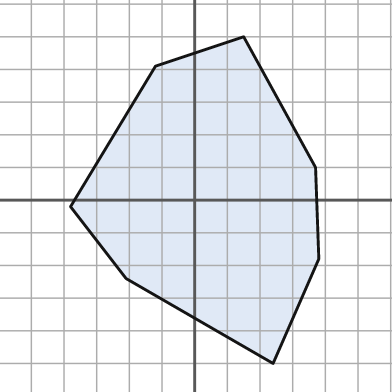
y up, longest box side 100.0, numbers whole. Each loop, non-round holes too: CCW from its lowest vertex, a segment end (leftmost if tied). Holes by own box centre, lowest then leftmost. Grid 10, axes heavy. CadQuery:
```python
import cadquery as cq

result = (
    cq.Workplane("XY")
    .moveTo(24.0, -50.0)
    .lineTo(38.0, -18.0)
    .lineTo(37.0, 10.0)
    .lineTo(15.0, 50.0)
    .lineTo(-12.0, 41.0)
    .lineTo(-38.0, -2.0)
    .lineTo(-21.0, -24.0)
    .close()
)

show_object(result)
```